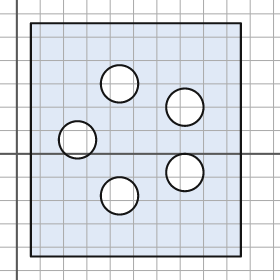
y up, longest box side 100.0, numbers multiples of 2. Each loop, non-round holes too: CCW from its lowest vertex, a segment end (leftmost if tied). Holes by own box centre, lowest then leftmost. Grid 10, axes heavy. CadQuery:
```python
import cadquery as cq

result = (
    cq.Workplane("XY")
    .moveTo(6.0, -44.0)
    .lineTo(96.0, -44.0)
    .lineTo(96.0, 56.0)
    .lineTo(6.0, 56.0)
    .close()
    .moveTo(44.0, -18.0)
    .circle(8.0)
    .moveTo(72.0, -8.0)
    .circle(8.0)
    .moveTo(26.0, 6.0)
    .circle(8.0)
    .moveTo(72.0, 20.0)
    .circle(8.0)
    .moveTo(44.0, 30.0)
    .circle(8.0)
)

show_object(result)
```